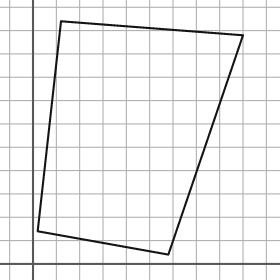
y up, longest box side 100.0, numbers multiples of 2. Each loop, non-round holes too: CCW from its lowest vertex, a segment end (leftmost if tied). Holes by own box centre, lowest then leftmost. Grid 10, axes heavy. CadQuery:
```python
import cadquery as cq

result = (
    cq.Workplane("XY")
    .moveTo(58.0, 4.0)
    .lineTo(90.0, 98.0)
    .lineTo(12.0, 104.0)
    .lineTo(2.0, 14.0)
    .close()
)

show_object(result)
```